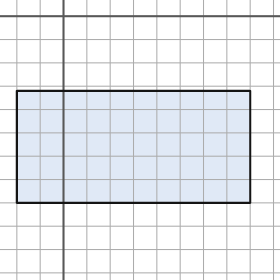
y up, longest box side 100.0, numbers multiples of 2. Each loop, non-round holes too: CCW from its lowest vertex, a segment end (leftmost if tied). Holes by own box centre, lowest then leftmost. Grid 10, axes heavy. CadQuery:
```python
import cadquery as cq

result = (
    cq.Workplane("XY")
    .moveTo(-20.0, -80.0)
    .lineTo(80.0, -80.0)
    .lineTo(80.0, -32.0)
    .lineTo(-20.0, -32.0)
    .close()
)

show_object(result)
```